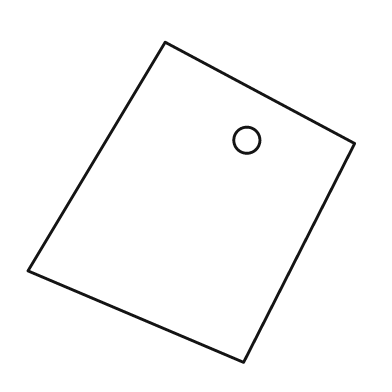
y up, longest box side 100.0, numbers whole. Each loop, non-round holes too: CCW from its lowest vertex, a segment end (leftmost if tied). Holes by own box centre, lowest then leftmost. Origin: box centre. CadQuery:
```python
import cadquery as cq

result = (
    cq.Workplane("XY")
    .moveTo(16.0, -49.0)
    .lineTo(50.0, 18.0)
    .lineTo(-8.0, 49.0)
    .lineTo(-50.0, -21.0)
    .close()
    .moveTo(17.0, 19.0)
    .circle(4.0)
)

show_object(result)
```